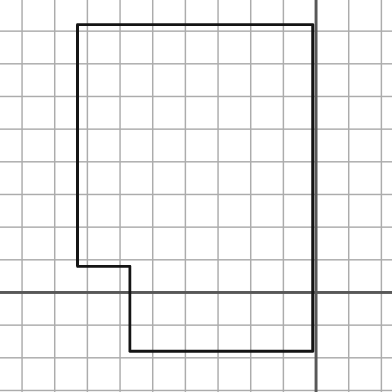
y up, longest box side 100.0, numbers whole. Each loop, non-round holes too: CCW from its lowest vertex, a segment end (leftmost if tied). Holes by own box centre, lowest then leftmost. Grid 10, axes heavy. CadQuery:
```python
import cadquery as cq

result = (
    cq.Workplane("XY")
    .moveTo(-57.0, -18.0)
    .lineTo(-1.0, -18.0)
    .lineTo(-1.0, 82.0)
    .lineTo(-73.0, 82.0)
    .lineTo(-73.0, 8.0)
    .lineTo(-57.0, 8.0)
    .close()
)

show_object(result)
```